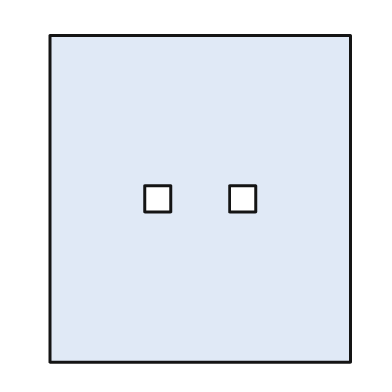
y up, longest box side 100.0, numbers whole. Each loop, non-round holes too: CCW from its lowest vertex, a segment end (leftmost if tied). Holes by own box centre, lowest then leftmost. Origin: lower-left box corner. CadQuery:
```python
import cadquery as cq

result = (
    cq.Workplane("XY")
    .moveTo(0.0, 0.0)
    .lineTo(92.0, 0.0)
    .lineTo(92.0, 100.0)
    .lineTo(0.0, 100.0)
    .close()
    .moveTo(29.0, 46.0)
    .lineTo(37.0, 46.0)
    .lineTo(37.0, 54.0)
    .lineTo(29.0, 54.0)
    .close()
    .moveTo(55.0, 46.0)
    .lineTo(63.0, 46.0)
    .lineTo(63.0, 54.0)
    .lineTo(55.0, 54.0)
    .close()
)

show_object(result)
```